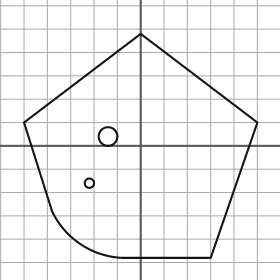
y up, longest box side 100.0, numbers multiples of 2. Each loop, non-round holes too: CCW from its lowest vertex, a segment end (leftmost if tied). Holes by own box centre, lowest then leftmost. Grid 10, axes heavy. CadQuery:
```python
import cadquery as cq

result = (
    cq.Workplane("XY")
    .moveTo(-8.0, -48.0)
    .lineTo(30.0, -48.0)
    .lineTo(50.0, 10.0)
    .lineTo(0.0, 48.0)
    .lineTo(-50.0, 10.0)
    .lineTo(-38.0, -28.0)
    .threePointArc((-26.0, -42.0), (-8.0, -48.0))
    .close()
    .moveTo(-22.0, -16.0)
    .circle(2.0)
    .moveTo(-14.0, 4.0)
    .circle(4.0)
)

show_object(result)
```